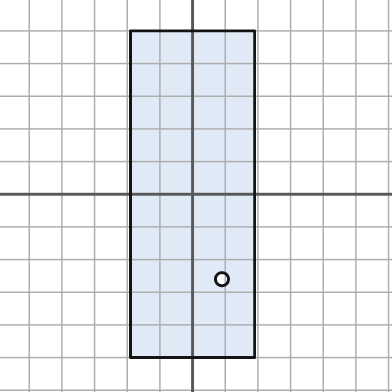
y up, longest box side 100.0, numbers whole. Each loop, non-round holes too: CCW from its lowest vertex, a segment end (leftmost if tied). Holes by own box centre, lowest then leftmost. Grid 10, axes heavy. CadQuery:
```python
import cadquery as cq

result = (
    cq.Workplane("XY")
    .moveTo(-19.0, -50.0)
    .lineTo(19.0, -50.0)
    .lineTo(19.0, 50.0)
    .lineTo(-19.0, 50.0)
    .close()
    .moveTo(9.0, -26.0)
    .circle(2.0)
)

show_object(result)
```